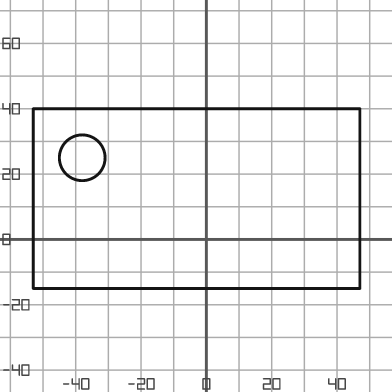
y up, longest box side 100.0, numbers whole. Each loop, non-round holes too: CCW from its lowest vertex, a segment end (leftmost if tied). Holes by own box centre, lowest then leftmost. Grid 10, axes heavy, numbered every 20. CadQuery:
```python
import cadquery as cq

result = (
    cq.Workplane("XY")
    .moveTo(-53.0, -15.0)
    .lineTo(47.0, -15.0)
    .lineTo(47.0, 40.0)
    .lineTo(-53.0, 40.0)
    .close()
    .moveTo(-38.0, 25.0)
    .circle(7.0)
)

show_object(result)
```